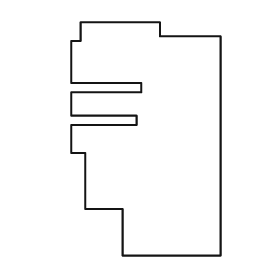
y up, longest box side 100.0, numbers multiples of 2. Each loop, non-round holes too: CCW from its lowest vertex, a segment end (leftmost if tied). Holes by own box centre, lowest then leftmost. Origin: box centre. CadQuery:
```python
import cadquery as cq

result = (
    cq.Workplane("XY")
    .moveTo(-10.0, -50.0)
    .lineTo(32.0, -50.0)
    .lineTo(32.0, 44.0)
    .lineTo(6.0, 44.0)
    .lineTo(6.0, 50.0)
    .lineTo(-28.0, 50.0)
    .lineTo(-28.0, 42.0)
    .lineTo(-32.0, 42.0)
    .lineTo(-32.0, 24.0)
    .lineTo(-2.0, 24.0)
    .lineTo(-2.0, 20.0)
    .lineTo(-32.0, 20.0)
    .lineTo(-32.0, 10.0)
    .lineTo(-4.0, 10.0)
    .lineTo(-4.0, 6.0)
    .lineTo(-32.0, 6.0)
    .lineTo(-32.0, -6.0)
    .lineTo(-26.0, -6.0)
    .lineTo(-26.0, -30.0)
    .lineTo(-10.0, -30.0)
    .close()
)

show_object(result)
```